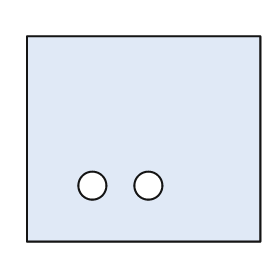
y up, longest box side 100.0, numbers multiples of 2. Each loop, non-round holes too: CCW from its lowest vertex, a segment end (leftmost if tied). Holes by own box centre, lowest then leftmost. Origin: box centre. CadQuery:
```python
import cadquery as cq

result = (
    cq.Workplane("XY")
    .moveTo(-50.0, -44.0)
    .lineTo(50.0, -44.0)
    .lineTo(50.0, 44.0)
    .lineTo(-50.0, 44.0)
    .close()
    .moveTo(-22.0, -20.0)
    .circle(6.0)
    .moveTo(2.0, -20.0)
    .circle(6.0)
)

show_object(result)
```